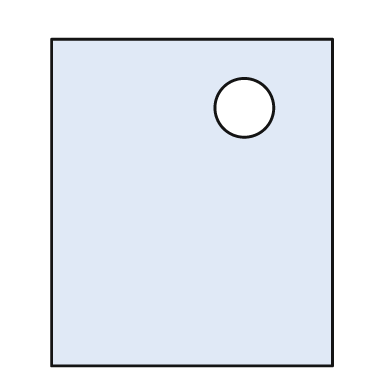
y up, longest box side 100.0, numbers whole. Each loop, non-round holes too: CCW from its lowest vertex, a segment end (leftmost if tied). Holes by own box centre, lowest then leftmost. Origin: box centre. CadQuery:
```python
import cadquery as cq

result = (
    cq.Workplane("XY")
    .moveTo(-43.0, -50.0)
    .lineTo(43.0, -50.0)
    .lineTo(43.0, 50.0)
    .lineTo(-43.0, 50.0)
    .close()
    .moveTo(16.0, 29.0)
    .circle(9.0)
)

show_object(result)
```